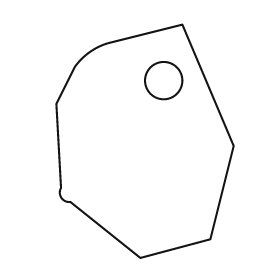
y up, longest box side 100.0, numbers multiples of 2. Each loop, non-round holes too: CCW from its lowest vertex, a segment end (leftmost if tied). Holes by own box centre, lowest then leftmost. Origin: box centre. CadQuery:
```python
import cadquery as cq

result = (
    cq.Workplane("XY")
    .moveTo(-2.0, -50.0)
    .lineTo(28.0, -42.0)
    .lineTo(38.0, -2.0)
    .lineTo(16.0, 50.0)
    .lineTo(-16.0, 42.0)
    .threePointArc((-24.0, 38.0), (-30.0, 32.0))
    .lineTo(-38.0, 16.0)
    .lineTo(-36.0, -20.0)
    .threePointArc((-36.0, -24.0), (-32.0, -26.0))
    .close()
    .moveTo(8.0, 26.0)
    .circle(8.0)
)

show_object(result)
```